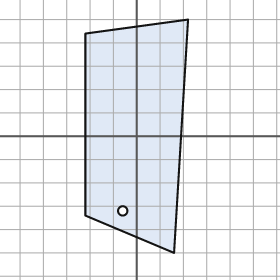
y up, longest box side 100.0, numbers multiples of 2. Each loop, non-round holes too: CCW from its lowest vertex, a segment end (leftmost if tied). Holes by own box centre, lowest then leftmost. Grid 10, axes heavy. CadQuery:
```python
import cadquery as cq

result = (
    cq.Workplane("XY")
    .moveTo(16.0, -50.0)
    .lineTo(22.0, 50.0)
    .lineTo(-22.0, 44.0)
    .lineTo(-22.0, -34.0)
    .close()
    .moveTo(-6.0, -32.0)
    .circle(2.0)
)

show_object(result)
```